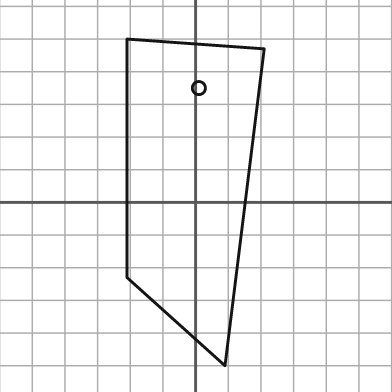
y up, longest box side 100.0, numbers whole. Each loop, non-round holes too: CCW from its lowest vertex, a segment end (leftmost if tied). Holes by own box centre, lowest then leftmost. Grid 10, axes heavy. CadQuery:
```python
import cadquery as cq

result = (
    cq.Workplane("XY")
    .moveTo(9.0, -50.0)
    .lineTo(21.0, 47.0)
    .lineTo(-21.0, 50.0)
    .lineTo(-21.0, -23.0)
    .close()
    .moveTo(1.0, 35.0)
    .circle(2.0)
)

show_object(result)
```